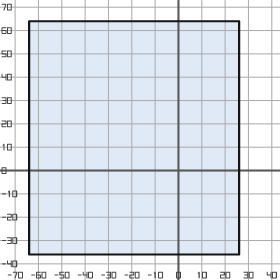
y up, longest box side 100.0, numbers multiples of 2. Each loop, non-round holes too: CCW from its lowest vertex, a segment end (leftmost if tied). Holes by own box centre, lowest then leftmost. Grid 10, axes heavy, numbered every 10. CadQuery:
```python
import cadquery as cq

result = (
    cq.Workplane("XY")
    .moveTo(-64.0, -36.0)
    .lineTo(26.0, -36.0)
    .lineTo(26.0, 64.0)
    .lineTo(-64.0, 64.0)
    .close()
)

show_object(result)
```